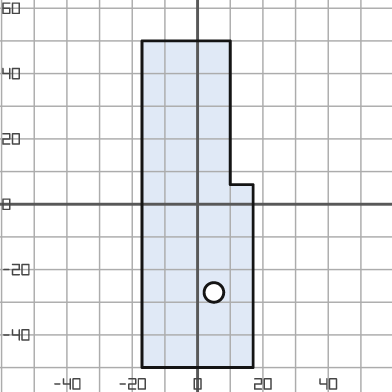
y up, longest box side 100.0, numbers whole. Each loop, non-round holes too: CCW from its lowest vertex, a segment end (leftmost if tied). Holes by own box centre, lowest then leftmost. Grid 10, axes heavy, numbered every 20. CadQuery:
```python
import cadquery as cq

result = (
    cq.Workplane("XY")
    .moveTo(-17.0, -50.0)
    .lineTo(17.0, -50.0)
    .lineTo(17.0, 6.0)
    .lineTo(10.0, 6.0)
    .lineTo(10.0, 50.0)
    .lineTo(-17.0, 50.0)
    .close()
    .moveTo(5.0, -27.0)
    .circle(3.0)
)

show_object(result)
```